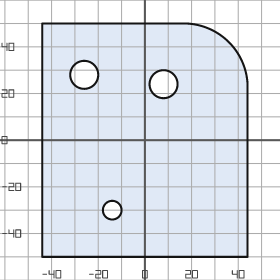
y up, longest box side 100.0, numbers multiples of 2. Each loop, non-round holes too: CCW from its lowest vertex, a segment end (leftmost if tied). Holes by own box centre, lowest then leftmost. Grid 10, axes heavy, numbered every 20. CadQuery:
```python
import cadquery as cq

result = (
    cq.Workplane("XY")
    .moveTo(-44.0, -50.0)
    .lineTo(44.0, -50.0)
    .lineTo(44.0, 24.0)
    .threePointArc((36.0, 42.0), (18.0, 50.0))
    .lineTo(-44.0, 50.0)
    .close()
    .moveTo(-14.0, -30.0)
    .circle(4.0)
    .moveTo(8.0, 24.0)
    .circle(6.0)
    .moveTo(-26.0, 28.0)
    .circle(6.0)
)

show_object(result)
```